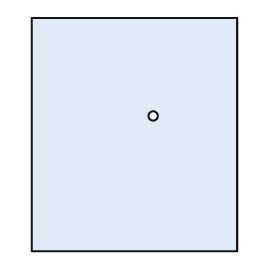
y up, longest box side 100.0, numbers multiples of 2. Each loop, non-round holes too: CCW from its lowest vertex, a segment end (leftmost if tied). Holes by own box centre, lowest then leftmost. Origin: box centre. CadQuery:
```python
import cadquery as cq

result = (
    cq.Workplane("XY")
    .moveTo(-44.0, -50.0)
    .lineTo(44.0, -50.0)
    .lineTo(44.0, 50.0)
    .lineTo(-44.0, 50.0)
    .close()
    .moveTo(8.0, 8.0)
    .circle(2.0)
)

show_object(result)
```